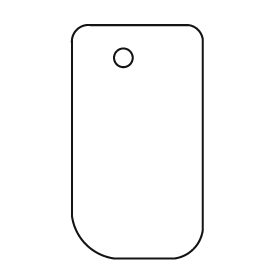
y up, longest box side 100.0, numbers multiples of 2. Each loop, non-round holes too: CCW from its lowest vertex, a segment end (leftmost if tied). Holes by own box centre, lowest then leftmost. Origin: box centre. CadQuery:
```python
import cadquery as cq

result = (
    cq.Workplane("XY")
    .moveTo(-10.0, -50.0)
    .lineTo(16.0, -50.0)
    .threePointArc((24.0, -46.0), (28.0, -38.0))
    .lineTo(28.0, 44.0)
    .threePointArc((26.0, 48.0), (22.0, 50.0))
    .lineTo(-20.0, 50.0)
    .threePointArc((-26.0, 48.0), (-28.0, 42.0))
    .lineTo(-28.0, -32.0)
    .threePointArc((-22.0, -44.0), (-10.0, -50.0))
    .close()
    .moveTo(-6.0, 36.0)
    .circle(4.0)
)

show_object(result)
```